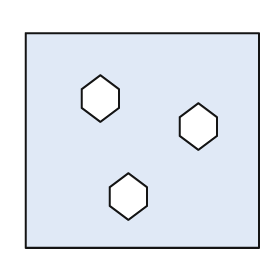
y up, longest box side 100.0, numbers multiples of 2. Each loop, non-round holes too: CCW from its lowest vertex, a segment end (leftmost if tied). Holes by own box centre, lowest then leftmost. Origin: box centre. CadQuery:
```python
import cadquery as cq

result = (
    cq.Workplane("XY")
    .moveTo(-50.0, -46.0)
    .lineTo(50.0, -46.0)
    .lineTo(50.0, 46.0)
    .lineTo(-50.0, 46.0)
    .close()
    .moveTo(-6.0, -34.0)
    .lineTo(2.0, -28.0)
    .lineTo(2.0, -20.0)
    .lineTo(-6.0, -14.0)
    .lineTo(-14.0, -20.0)
    .lineTo(-14.0, -28.0)
    .close()
    .moveTo(24.0, -4.0)
    .lineTo(32.0, 2.0)
    .lineTo(32.0, 10.0)
    .lineTo(24.0, 16.0)
    .lineTo(16.0, 10.0)
    .lineTo(16.0, 2.0)
    .close()
    .moveTo(-18.0, 8.0)
    .lineTo(-10.0, 14.0)
    .lineTo(-10.0, 22.0)
    .lineTo(-18.0, 28.0)
    .lineTo(-26.0, 22.0)
    .lineTo(-26.0, 14.0)
    .close()
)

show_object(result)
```